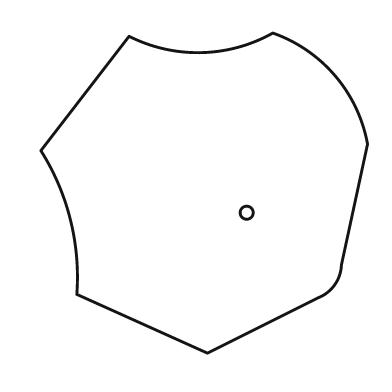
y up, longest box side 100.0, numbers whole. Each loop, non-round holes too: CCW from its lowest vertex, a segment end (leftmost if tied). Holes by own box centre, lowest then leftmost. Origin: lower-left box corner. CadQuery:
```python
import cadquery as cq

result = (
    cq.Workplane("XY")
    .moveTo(51.0, 0.0)
    .lineTo(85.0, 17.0)
    .threePointArc((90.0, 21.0), (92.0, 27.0))
    .lineTo(100.0, 64.0)
    .threePointArc((90.0, 85.0), (71.0, 98.0))
    .threePointArc((49.0, 92.0), (27.0, 97.0))
    .lineTo(0.0, 62.0)
    .threePointArc((9.0, 41.0), (11.0, 18.0))
    .close()
    .moveTo(63.0, 43.0)
    .circle(2.0)
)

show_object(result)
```